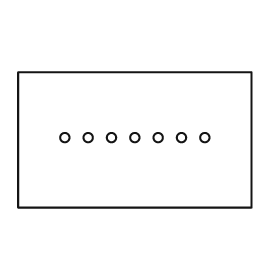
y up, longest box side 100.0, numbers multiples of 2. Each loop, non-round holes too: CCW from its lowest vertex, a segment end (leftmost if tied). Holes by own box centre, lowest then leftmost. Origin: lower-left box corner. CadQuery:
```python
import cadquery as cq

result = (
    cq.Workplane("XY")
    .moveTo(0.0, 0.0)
    .lineTo(100.0, 0.0)
    .lineTo(100.0, 58.0)
    .lineTo(0.0, 58.0)
    .close()
    .moveTo(20.0, 30.0)
    .circle(2.0)
    .moveTo(30.0, 30.0)
    .circle(2.0)
    .moveTo(40.0, 30.0)
    .circle(2.0)
    .moveTo(50.0, 30.0)
    .circle(2.0)
    .moveTo(60.0, 30.0)
    .circle(2.0)
    .moveTo(70.0, 30.0)
    .circle(2.0)
    .moveTo(80.0, 30.0)
    .circle(2.0)
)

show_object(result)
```